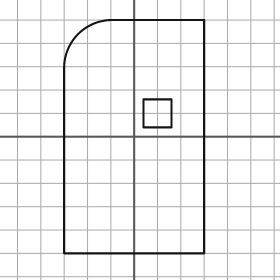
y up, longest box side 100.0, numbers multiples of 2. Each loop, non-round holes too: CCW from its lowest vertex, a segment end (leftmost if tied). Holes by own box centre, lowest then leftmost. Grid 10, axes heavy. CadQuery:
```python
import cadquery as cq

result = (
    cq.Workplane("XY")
    .moveTo(-30.0, -50.0)
    .lineTo(30.0, -50.0)
    .lineTo(30.0, 50.0)
    .lineTo(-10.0, 50.0)
    .threePointArc((-24.0, 44.0), (-30.0, 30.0))
    .close()
    .moveTo(4.0, 4.0)
    .lineTo(16.0, 4.0)
    .lineTo(16.0, 16.0)
    .lineTo(4.0, 16.0)
    .close()
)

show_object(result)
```